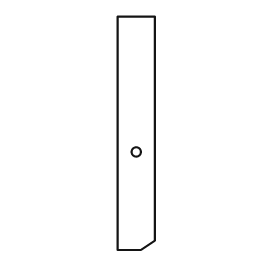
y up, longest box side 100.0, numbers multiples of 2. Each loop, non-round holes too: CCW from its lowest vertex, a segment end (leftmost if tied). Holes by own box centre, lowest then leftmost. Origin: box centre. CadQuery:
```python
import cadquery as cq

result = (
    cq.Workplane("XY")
    .moveTo(-8.0, -50.0)
    .lineTo(2.0, -50.0)
    .lineTo(8.0, -46.0)
    .lineTo(8.0, 50.0)
    .lineTo(-8.0, 50.0)
    .close()
    .moveTo(0.0, -8.0)
    .circle(2.0)
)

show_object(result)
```